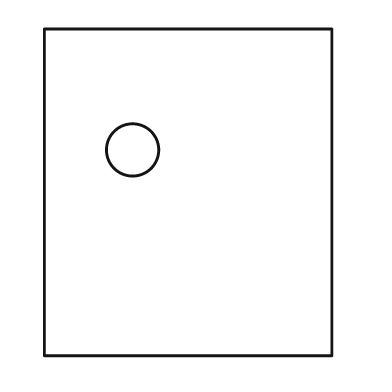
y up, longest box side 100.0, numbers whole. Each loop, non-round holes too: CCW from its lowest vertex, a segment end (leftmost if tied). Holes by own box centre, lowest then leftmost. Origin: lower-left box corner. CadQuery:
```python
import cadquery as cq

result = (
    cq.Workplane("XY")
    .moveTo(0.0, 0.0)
    .lineTo(88.0, 0.0)
    .lineTo(88.0, 100.0)
    .lineTo(0.0, 100.0)
    .close()
    .moveTo(27.0, 63.0)
    .circle(8.0)
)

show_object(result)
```